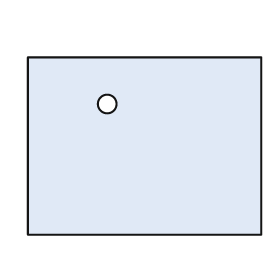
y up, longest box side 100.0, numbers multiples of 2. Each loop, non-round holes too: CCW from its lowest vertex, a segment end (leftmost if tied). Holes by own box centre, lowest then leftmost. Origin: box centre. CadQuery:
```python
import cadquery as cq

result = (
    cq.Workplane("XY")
    .moveTo(-50.0, -38.0)
    .lineTo(50.0, -38.0)
    .lineTo(50.0, 38.0)
    .lineTo(-50.0, 38.0)
    .close()
    .moveTo(-16.0, 18.0)
    .circle(4.0)
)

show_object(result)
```